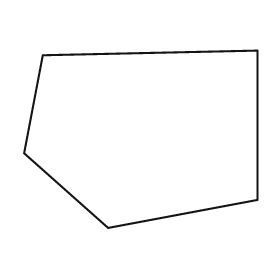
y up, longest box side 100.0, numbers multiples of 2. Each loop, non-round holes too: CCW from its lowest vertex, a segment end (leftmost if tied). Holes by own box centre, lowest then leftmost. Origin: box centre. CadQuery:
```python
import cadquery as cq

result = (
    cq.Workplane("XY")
    .moveTo(-14.0, -38.0)
    .lineTo(50.0, -26.0)
    .lineTo(50.0, 38.0)
    .lineTo(-42.0, 36.0)
    .lineTo(-50.0, -6.0)
    .close()
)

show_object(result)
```